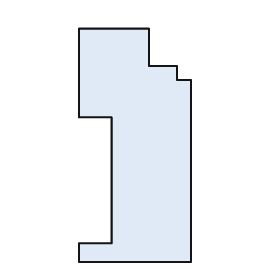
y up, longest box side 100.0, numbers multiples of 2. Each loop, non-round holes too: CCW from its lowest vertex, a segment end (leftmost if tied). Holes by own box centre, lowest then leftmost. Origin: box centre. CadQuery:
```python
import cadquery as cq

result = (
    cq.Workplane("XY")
    .moveTo(-24.0, -50.0)
    .lineTo(24.0, -50.0)
    .lineTo(24.0, 28.0)
    .lineTo(18.0, 28.0)
    .lineTo(18.0, 34.0)
    .lineTo(6.0, 34.0)
    .lineTo(6.0, 50.0)
    .lineTo(-24.0, 50.0)
    .lineTo(-24.0, 12.0)
    .lineTo(-10.0, 12.0)
    .lineTo(-10.0, -42.0)
    .lineTo(-24.0, -42.0)
    .close()
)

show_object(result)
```